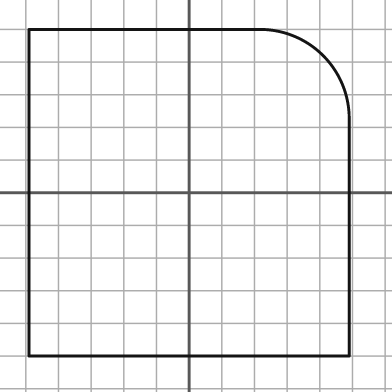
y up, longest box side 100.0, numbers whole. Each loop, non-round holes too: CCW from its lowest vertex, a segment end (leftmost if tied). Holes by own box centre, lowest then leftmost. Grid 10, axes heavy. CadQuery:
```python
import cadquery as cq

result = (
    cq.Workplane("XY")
    .moveTo(-49.0, -50.0)
    .lineTo(49.0, -50.0)
    .lineTo(49.0, 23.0)
    .threePointArc((41.0, 42.0), (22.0, 50.0))
    .lineTo(-49.0, 50.0)
    .close()
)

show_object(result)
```